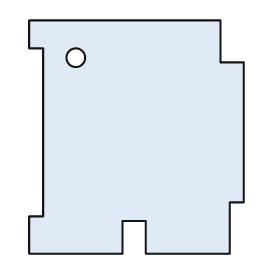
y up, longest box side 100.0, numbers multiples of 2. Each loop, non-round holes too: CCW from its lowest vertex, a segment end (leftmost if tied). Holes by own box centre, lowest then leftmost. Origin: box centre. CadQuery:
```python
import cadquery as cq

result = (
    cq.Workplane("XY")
    .moveTo(-46.0, -50.0)
    .lineTo(-6.0, -50.0)
    .lineTo(-6.0, -36.0)
    .lineTo(4.0, -36.0)
    .lineTo(4.0, -50.0)
    .lineTo(40.0, -50.0)
    .lineTo(40.0, -28.0)
    .lineTo(46.0, -28.0)
    .lineTo(46.0, 32.0)
    .lineTo(36.0, 32.0)
    .lineTo(36.0, 50.0)
    .lineTo(-46.0, 50.0)
    .lineTo(-46.0, 38.0)
    .lineTo(-40.0, 38.0)
    .lineTo(-40.0, -34.0)
    .lineTo(-46.0, -34.0)
    .close()
    .moveTo(-26.0, 34.0)
    .circle(4.0)
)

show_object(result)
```